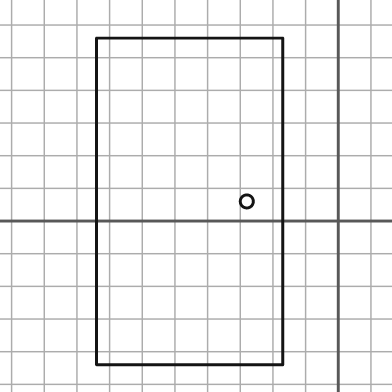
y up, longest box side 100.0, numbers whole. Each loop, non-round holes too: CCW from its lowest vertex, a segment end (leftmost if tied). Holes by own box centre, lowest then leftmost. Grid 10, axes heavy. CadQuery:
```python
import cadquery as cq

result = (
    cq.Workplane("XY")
    .moveTo(-74.0, -44.0)
    .lineTo(-17.0, -44.0)
    .lineTo(-17.0, 56.0)
    .lineTo(-74.0, 56.0)
    .close()
    .moveTo(-28.0, 6.0)
    .circle(2.0)
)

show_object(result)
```